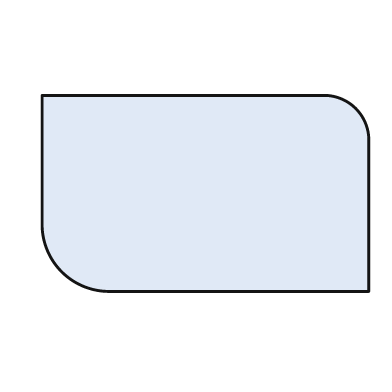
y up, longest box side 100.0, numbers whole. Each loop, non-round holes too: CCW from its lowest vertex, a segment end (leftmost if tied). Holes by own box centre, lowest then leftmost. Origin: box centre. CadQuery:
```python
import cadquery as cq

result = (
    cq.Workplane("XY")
    .moveTo(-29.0, -30.0)
    .lineTo(50.0, -30.0)
    .lineTo(50.0, 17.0)
    .threePointArc((46.0, 26.0), (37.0, 30.0))
    .lineTo(-50.0, 30.0)
    .lineTo(-50.0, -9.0)
    .threePointArc((-44.0, -24.0), (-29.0, -30.0))
    .close()
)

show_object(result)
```